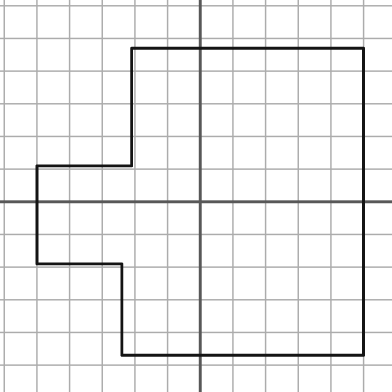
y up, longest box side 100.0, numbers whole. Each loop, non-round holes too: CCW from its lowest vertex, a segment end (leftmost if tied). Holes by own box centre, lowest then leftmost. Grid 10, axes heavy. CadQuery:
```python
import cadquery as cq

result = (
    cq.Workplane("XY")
    .moveTo(-24.0, -47.0)
    .lineTo(50.0, -47.0)
    .lineTo(50.0, 47.0)
    .lineTo(-21.0, 47.0)
    .lineTo(-21.0, 11.0)
    .lineTo(-50.0, 11.0)
    .lineTo(-50.0, -19.0)
    .lineTo(-24.0, -19.0)
    .close()
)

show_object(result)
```